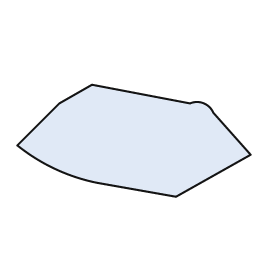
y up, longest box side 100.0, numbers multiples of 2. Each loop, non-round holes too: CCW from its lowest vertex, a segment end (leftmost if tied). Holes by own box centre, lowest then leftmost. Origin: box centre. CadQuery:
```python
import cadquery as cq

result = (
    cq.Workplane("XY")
    .moveTo(18.0, -24.0)
    .lineTo(50.0, -6.0)
    .lineTo(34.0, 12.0)
    .threePointArc((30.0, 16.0), (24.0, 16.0))
    .lineTo(-18.0, 24.0)
    .lineTo(-32.0, 16.0)
    .lineTo(-50.0, -2.0)
    .threePointArc((-34.0, -12.0), (-16.0, -18.0))
    .close()
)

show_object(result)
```